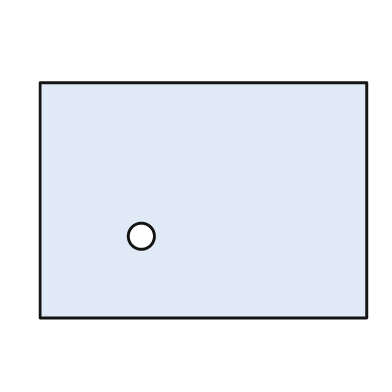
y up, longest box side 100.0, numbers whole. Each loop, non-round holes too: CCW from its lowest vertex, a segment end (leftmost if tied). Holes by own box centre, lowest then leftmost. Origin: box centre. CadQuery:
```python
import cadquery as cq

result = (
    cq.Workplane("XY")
    .moveTo(-50.0, -36.0)
    .lineTo(50.0, -36.0)
    .lineTo(50.0, 36.0)
    .lineTo(-50.0, 36.0)
    .close()
    .moveTo(-19.0, -11.0)
    .circle(4.0)
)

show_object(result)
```